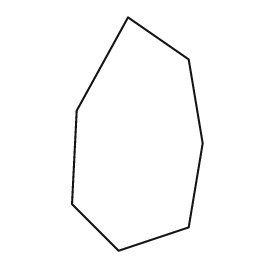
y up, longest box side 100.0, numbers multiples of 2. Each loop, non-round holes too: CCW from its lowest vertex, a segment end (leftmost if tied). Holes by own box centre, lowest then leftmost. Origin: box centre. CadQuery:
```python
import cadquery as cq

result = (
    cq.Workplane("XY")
    .moveTo(-8.0, -50.0)
    .lineTo(22.0, -40.0)
    .lineTo(28.0, -4.0)
    .lineTo(22.0, 32.0)
    .lineTo(-4.0, 50.0)
    .lineTo(-26.0, 10.0)
    .lineTo(-28.0, -30.0)
    .close()
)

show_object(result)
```